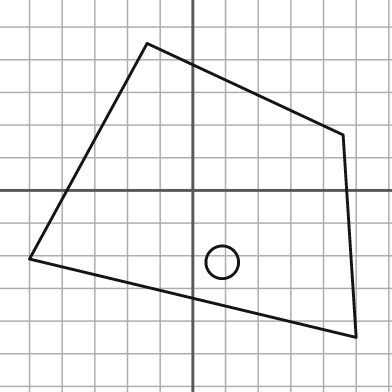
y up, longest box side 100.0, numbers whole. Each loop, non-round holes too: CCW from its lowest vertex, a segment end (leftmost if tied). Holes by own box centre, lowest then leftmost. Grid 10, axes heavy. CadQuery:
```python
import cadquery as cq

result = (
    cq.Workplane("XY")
    .moveTo(50.0, -45.0)
    .lineTo(46.0, 17.0)
    .lineTo(-14.0, 45.0)
    .lineTo(-50.0, -21.0)
    .close()
    .moveTo(9.0, -22.0)
    .circle(5.0)
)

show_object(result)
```